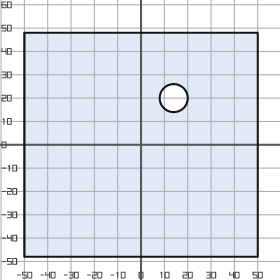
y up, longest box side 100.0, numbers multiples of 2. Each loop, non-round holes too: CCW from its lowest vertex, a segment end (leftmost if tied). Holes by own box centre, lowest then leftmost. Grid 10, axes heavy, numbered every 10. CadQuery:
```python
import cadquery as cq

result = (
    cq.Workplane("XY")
    .moveTo(-50.0, -48.0)
    .lineTo(50.0, -48.0)
    .lineTo(50.0, 48.0)
    .lineTo(-50.0, 48.0)
    .close()
    .moveTo(14.0, 20.0)
    .circle(6.0)
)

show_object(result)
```